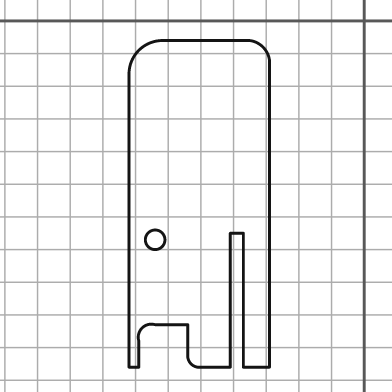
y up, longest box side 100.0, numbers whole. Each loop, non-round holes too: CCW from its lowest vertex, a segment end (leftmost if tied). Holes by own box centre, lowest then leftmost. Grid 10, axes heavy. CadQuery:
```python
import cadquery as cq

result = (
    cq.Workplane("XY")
    .moveTo(-72.0, -106.0)
    .lineTo(-69.0, -106.0)
    .lineTo(-69.0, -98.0)
    .threePointArc((-68.0, -94.0), (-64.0, -93.0))
    .lineTo(-54.0, -93.0)
    .lineTo(-54.0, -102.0)
    .threePointArc((-53.0, -105.0), (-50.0, -106.0))
    .lineTo(-41.0, -106.0)
    .lineTo(-41.0, -65.0)
    .lineTo(-37.0, -65.0)
    .lineTo(-37.0, -106.0)
    .lineTo(-29.0, -106.0)
    .lineTo(-29.0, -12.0)
    .threePointArc((-31.0, -8.0), (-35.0, -6.0))
    .lineTo(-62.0, -6.0)
    .threePointArc((-69.0, -9.0), (-72.0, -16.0))
    .close()
    .moveTo(-64.0, -67.0)
    .circle(3.0)
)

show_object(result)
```